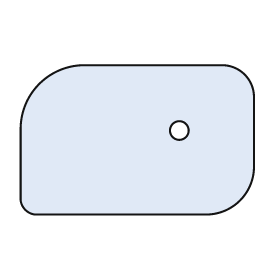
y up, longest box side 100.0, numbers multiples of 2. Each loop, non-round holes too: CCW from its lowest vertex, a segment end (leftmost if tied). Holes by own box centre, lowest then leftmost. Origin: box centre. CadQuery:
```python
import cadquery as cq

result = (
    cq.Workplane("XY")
    .moveTo(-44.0, -32.0)
    .lineTo(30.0, -32.0)
    .threePointArc((44.0, -26.0), (50.0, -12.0))
    .lineTo(50.0, 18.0)
    .threePointArc((46.0, 28.0), (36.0, 32.0))
    .lineTo(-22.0, 32.0)
    .threePointArc((-42.0, 24.0), (-50.0, 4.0))
    .lineTo(-50.0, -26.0)
    .threePointArc((-48.0, -30.0), (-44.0, -32.0))
    .close()
    .moveTo(18.0, 4.0)
    .circle(4.0)
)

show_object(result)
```